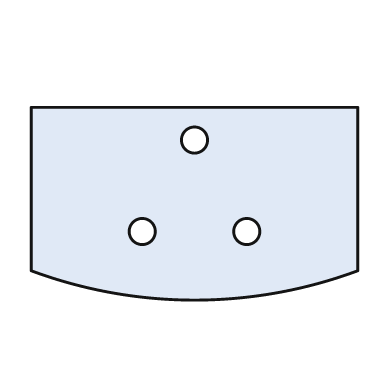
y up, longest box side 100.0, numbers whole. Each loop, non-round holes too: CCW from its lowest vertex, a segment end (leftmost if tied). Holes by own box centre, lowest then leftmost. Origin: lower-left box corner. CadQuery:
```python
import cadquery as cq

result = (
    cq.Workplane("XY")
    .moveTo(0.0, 9.0)
    .threePointArc((50.0, 0.0), (100.0, 9.0))
    .lineTo(100.0, 59.0)
    .lineTo(0.0, 59.0)
    .close()
    .moveTo(34.0, 21.0)
    .circle(4.0)
    .moveTo(66.0, 21.0)
    .circle(4.0)
    .moveTo(50.0, 49.0)
    .circle(4.0)
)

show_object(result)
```